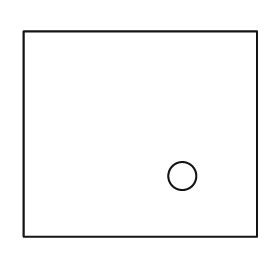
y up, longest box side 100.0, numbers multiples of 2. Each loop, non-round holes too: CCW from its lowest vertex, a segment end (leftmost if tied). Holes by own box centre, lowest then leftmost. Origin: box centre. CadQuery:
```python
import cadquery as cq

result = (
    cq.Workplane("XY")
    .moveTo(-50.0, -44.0)
    .lineTo(50.0, -44.0)
    .lineTo(50.0, 44.0)
    .lineTo(-50.0, 44.0)
    .close()
    .moveTo(18.0, -18.0)
    .circle(6.0)
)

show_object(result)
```